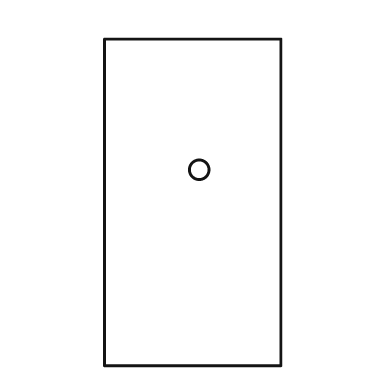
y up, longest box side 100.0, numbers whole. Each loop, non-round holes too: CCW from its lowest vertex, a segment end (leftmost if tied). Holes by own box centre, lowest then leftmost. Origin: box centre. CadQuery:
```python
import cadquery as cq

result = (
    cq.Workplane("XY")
    .moveTo(-27.0, -50.0)
    .lineTo(27.0, -50.0)
    .lineTo(27.0, 50.0)
    .lineTo(-27.0, 50.0)
    .close()
    .moveTo(2.0, 10.0)
    .circle(3.0)
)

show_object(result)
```